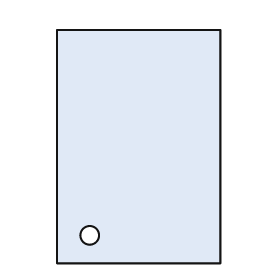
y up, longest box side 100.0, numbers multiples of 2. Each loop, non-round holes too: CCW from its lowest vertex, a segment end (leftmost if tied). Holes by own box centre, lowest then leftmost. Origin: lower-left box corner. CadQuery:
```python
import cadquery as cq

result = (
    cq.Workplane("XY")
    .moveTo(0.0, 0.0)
    .lineTo(70.0, 0.0)
    .lineTo(70.0, 100.0)
    .lineTo(0.0, 100.0)
    .close()
    .moveTo(14.0, 12.0)
    .circle(4.0)
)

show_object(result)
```